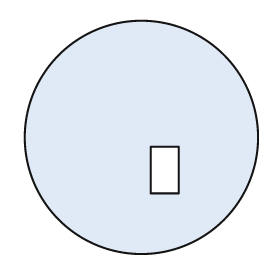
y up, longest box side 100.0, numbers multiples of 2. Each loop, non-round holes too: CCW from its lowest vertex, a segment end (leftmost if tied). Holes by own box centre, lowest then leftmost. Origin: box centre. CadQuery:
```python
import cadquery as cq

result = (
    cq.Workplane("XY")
    .moveTo(0.0, 0.0)
    .circle(50.0)
    .moveTo(4.0, -24.0)
    .lineTo(16.0, -24.0)
    .lineTo(16.0, -4.0)
    .lineTo(4.0, -4.0)
    .close()
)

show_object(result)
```